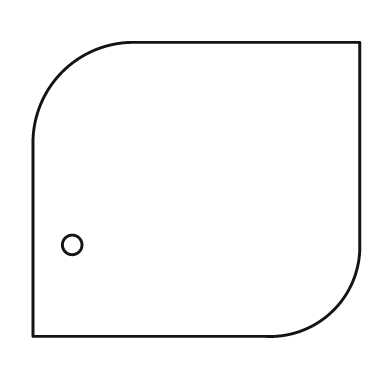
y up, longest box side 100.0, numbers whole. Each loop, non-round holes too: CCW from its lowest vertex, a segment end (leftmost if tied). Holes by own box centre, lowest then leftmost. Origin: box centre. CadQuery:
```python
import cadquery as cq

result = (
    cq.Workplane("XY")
    .moveTo(-50.0, -45.0)
    .lineTo(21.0, -45.0)
    .threePointArc((42.0, -37.0), (50.0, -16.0))
    .lineTo(50.0, 45.0)
    .lineTo(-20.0, 45.0)
    .threePointArc((-41.0, 36.0), (-50.0, 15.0))
    .close()
    .moveTo(-38.0, -17.0)
    .circle(3.0)
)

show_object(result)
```